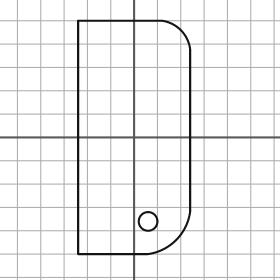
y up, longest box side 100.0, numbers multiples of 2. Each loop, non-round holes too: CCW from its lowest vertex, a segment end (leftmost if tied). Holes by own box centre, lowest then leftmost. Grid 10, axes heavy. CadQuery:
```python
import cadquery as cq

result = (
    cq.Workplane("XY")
    .moveTo(-24.0, -50.0)
    .lineTo(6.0, -50.0)
    .threePointArc((18.0, -44.0), (24.0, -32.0))
    .lineTo(24.0, 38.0)
    .threePointArc((20.0, 46.0), (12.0, 50.0))
    .lineTo(-24.0, 50.0)
    .close()
    .moveTo(6.0, -36.0)
    .circle(4.0)
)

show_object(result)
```